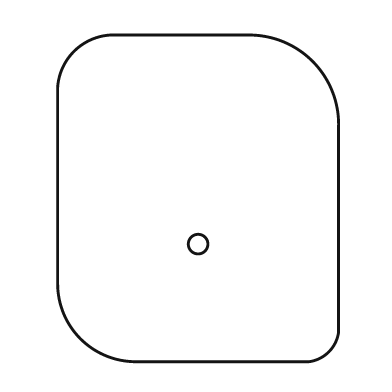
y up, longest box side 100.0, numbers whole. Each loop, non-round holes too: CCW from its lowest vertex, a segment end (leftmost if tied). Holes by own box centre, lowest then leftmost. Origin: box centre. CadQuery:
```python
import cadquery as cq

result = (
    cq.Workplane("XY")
    .moveTo(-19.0, -50.0)
    .lineTo(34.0, -50.0)
    .threePointArc((40.0, -47.0), (43.0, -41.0))
    .lineTo(43.0, 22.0)
    .threePointArc((35.0, 42.0), (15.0, 50.0))
    .lineTo(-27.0, 50.0)
    .threePointArc((-38.0, 45.0), (-43.0, 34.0))
    .lineTo(-43.0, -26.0)
    .threePointArc((-36.0, -43.0), (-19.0, -50.0))
    .close()
    .moveTo(0.0, -14.0)
    .circle(3.0)
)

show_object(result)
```